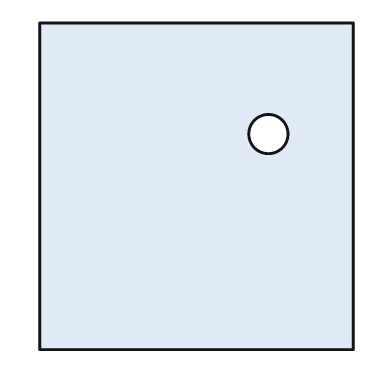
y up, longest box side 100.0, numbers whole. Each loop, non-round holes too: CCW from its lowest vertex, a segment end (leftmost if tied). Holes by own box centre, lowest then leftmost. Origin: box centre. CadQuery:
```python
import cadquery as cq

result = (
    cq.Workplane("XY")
    .moveTo(-48.0, -50.0)
    .lineTo(48.0, -50.0)
    .lineTo(48.0, 50.0)
    .lineTo(-48.0, 50.0)
    .close()
    .moveTo(22.0, 16.0)
    .circle(6.0)
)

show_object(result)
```